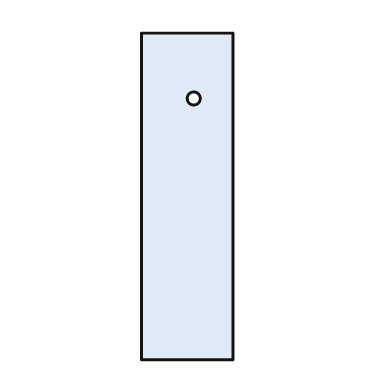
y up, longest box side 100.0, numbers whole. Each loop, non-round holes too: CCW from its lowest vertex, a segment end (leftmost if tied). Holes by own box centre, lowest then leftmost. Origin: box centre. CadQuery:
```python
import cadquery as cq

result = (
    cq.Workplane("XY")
    .moveTo(-14.0, -50.0)
    .lineTo(14.0, -50.0)
    .lineTo(14.0, 50.0)
    .lineTo(-14.0, 50.0)
    .close()
    .moveTo(2.0, 30.0)
    .circle(2.0)
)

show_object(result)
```